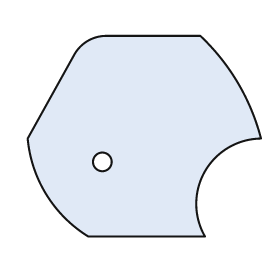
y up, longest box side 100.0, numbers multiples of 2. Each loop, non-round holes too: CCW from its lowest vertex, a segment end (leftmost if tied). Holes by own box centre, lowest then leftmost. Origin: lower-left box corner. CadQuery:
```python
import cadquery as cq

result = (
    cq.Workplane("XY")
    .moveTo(26.0, 0.0)
    .lineTo(76.0, 0.0)
    .threePointArc((76.0, 28.0), (100.0, 42.0))
    .threePointArc((90.0, 66.0), (74.0, 86.0))
    .lineTo(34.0, 86.0)
    .threePointArc((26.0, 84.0), (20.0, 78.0))
    .lineTo(0.0, 42.0)
    .threePointArc((8.0, 18.0), (26.0, 0.0))
    .close()
    .moveTo(32.0, 32.0)
    .circle(4.0)
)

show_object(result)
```